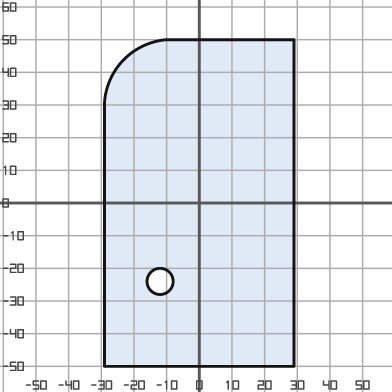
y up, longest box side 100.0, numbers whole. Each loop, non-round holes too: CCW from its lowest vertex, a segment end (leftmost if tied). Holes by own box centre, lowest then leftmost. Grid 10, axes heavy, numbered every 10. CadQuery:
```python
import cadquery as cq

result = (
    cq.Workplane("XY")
    .moveTo(-29.0, -50.0)
    .lineTo(29.0, -50.0)
    .lineTo(29.0, 50.0)
    .lineTo(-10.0, 50.0)
    .threePointArc((-23.0, 44.0), (-29.0, 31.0))
    .close()
    .moveTo(-12.0, -24.0)
    .circle(4.0)
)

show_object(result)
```